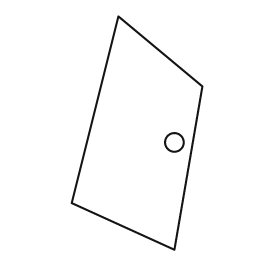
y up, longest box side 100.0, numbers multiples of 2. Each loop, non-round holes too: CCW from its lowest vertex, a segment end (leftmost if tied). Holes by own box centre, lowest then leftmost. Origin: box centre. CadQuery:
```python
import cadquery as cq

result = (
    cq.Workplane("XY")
    .moveTo(16.0, -50.0)
    .lineTo(28.0, 20.0)
    .lineTo(-8.0, 50.0)
    .lineTo(-28.0, -30.0)
    .close()
    .moveTo(16.0, -4.0)
    .circle(4.0)
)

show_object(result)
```